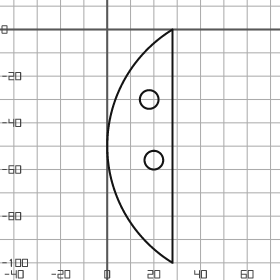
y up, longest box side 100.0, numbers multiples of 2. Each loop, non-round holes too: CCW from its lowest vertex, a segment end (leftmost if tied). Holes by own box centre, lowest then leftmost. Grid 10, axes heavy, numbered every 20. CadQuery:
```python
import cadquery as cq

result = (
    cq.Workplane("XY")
    .moveTo(28.0, -100.0)
    .lineTo(28.0, 0.0)
    .threePointArc((0.0, -50.0), (28.0, -100.0))
    .close()
    .moveTo(20.0, -56.0)
    .circle(4.0)
    .moveTo(18.0, -30.0)
    .circle(4.0)
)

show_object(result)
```